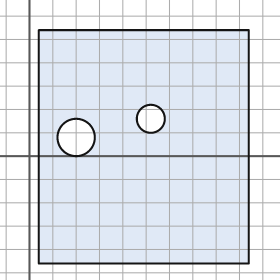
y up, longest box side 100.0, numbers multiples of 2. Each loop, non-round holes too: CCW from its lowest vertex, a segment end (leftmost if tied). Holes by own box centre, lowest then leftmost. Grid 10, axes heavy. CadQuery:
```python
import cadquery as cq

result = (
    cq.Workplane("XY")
    .moveTo(4.0, -46.0)
    .lineTo(94.0, -46.0)
    .lineTo(94.0, 54.0)
    .lineTo(4.0, 54.0)
    .close()
    .moveTo(20.0, 8.0)
    .circle(8.0)
    .moveTo(52.0, 16.0)
    .circle(6.0)
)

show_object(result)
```